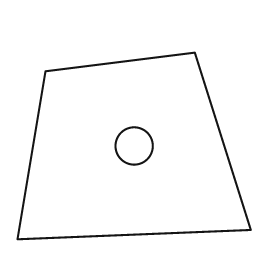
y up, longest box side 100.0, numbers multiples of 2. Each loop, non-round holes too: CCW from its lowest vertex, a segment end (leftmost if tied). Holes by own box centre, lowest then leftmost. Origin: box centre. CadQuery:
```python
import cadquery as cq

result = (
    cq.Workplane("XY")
    .moveTo(-50.0, -40.0)
    .lineTo(50.0, -36.0)
    .lineTo(26.0, 40.0)
    .lineTo(-38.0, 32.0)
    .close()
    .moveTo(0.0, 0.0)
    .circle(8.0)
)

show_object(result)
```